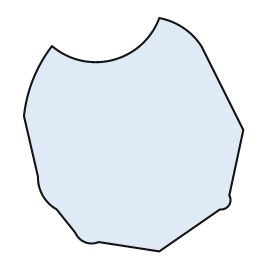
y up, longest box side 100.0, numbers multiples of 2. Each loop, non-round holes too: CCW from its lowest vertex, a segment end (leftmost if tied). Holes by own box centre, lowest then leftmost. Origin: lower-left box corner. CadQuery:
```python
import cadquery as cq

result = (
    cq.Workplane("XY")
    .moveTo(58.0, 0.0)
    .lineTo(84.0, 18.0)
    .threePointArc((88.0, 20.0), (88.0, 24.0))
    .lineTo(94.0, 52.0)
    .lineTo(76.0, 88.0)
    .threePointArc((68.0, 96.0), (58.0, 100.0))
    .threePointArc((38.0, 82.0), (12.0, 88.0))
    .threePointArc((4.0, 74.0), (0.0, 58.0))
    .lineTo(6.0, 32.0)
    .threePointArc((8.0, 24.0), (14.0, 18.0))
    .lineTo(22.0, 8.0)
    .threePointArc((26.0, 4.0), (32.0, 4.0))
    .close()
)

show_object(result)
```